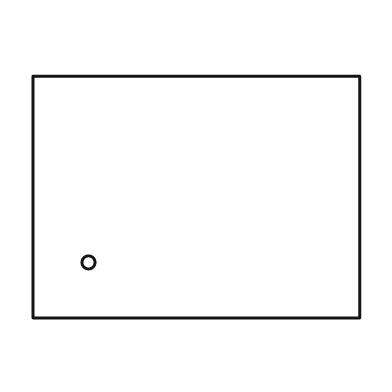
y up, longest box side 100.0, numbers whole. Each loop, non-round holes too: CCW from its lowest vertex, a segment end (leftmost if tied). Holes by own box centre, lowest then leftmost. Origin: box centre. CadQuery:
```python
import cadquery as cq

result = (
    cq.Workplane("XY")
    .moveTo(-50.0, -37.0)
    .lineTo(50.0, -37.0)
    .lineTo(50.0, 37.0)
    .lineTo(-50.0, 37.0)
    .close()
    .moveTo(-33.0, -20.0)
    .circle(2.0)
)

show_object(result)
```